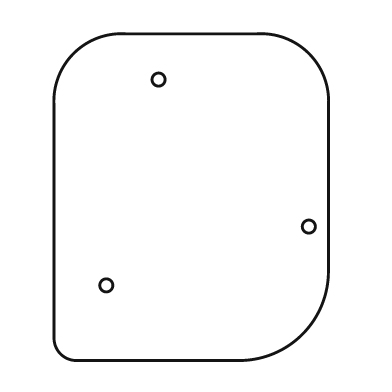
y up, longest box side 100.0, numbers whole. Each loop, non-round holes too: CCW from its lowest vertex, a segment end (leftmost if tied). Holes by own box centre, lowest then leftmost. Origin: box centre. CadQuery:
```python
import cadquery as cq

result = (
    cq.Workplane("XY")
    .moveTo(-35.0, -50.0)
    .lineTo(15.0, -50.0)
    .threePointArc((34.0, -42.0), (42.0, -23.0))
    .lineTo(42.0, 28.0)
    .threePointArc((36.0, 44.0), (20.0, 50.0))
    .lineTo(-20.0, 50.0)
    .threePointArc((-36.0, 44.0), (-42.0, 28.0))
    .lineTo(-42.0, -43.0)
    .threePointArc((-40.0, -48.0), (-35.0, -50.0))
    .close()
    .moveTo(-26.0, -27.0)
    .circle(2.0)
    .moveTo(36.0, -9.0)
    .circle(2.0)
    .moveTo(-10.0, 36.0)
    .circle(2.0)
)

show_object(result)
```